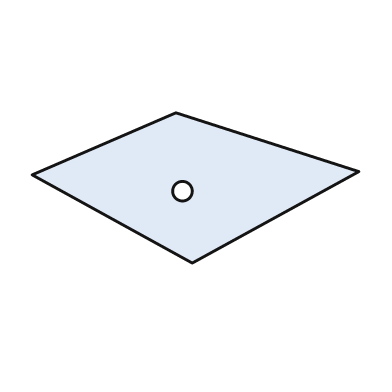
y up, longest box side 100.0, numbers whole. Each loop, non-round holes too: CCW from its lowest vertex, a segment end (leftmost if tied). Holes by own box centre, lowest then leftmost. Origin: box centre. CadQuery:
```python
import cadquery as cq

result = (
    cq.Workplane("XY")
    .moveTo(-1.0, -23.0)
    .lineTo(50.0, 5.0)
    .lineTo(-6.0, 23.0)
    .lineTo(-50.0, 4.0)
    .close()
    .moveTo(-4.0, -1.0)
    .circle(3.0)
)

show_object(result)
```